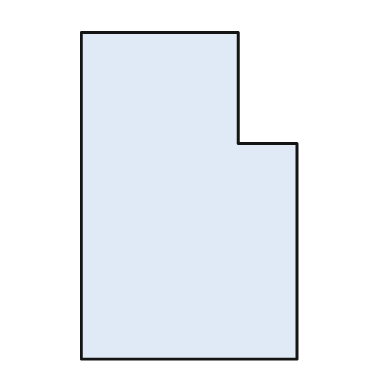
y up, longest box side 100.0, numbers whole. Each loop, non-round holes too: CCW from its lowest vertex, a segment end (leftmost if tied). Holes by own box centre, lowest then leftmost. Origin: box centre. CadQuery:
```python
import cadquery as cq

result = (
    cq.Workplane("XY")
    .moveTo(-33.0, -50.0)
    .lineTo(33.0, -50.0)
    .lineTo(33.0, 16.0)
    .lineTo(15.0, 16.0)
    .lineTo(15.0, 50.0)
    .lineTo(-33.0, 50.0)
    .close()
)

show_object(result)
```